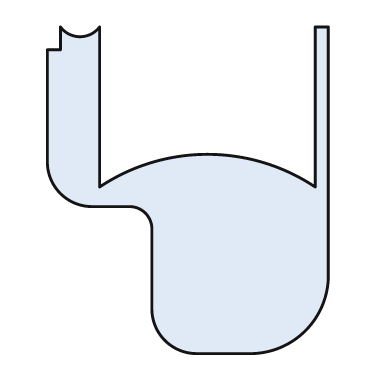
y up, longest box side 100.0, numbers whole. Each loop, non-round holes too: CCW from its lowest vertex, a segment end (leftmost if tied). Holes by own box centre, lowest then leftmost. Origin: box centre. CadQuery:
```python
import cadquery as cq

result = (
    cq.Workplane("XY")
    .moveTo(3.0, -50.0)
    .lineTo(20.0, -50.0)
    .threePointArc((36.0, -43.0), (43.0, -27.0))
    .lineTo(43.0, 50.0)
    .lineTo(39.0, 50.0)
    .lineTo(39.0, 1.0)
    .threePointArc((6.0, 11.0), (-27.0, 1.0))
    .lineTo(-27.0, 50.0)
    .threePointArc((-33.0, 47.0), (-39.0, 50.0))
    .lineTo(-39.0, 43.0)
    .lineTo(-43.0, 43.0)
    .lineTo(-43.0, 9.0)
    .threePointArc((-39.0, -1.0), (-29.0, -5.0))
    .lineTo(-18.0, -5.0)
    .threePointArc((-13.0, -7.0), (-11.0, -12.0))
    .lineTo(-11.0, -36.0)
    .threePointArc((-7.0, -46.0), (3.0, -50.0))
    .close()
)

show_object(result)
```